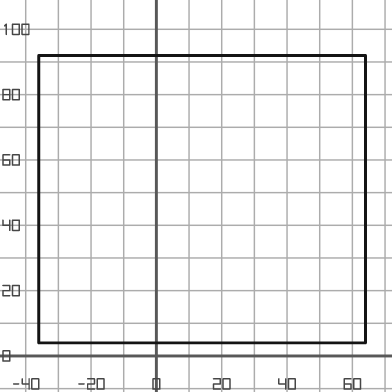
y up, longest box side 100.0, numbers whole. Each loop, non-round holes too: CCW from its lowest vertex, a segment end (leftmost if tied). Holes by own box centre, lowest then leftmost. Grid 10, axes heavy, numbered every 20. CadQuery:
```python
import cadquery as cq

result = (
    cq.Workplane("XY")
    .moveTo(-36.0, 4.0)
    .lineTo(64.0, 4.0)
    .lineTo(64.0, 92.0)
    .lineTo(-36.0, 92.0)
    .close()
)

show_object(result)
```